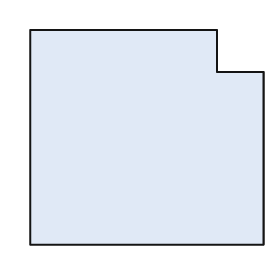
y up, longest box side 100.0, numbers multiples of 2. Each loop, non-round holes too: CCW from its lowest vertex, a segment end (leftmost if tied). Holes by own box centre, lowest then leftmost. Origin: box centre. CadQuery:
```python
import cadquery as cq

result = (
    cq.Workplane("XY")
    .moveTo(-50.0, -46.0)
    .lineTo(50.0, -46.0)
    .lineTo(50.0, 28.0)
    .lineTo(30.0, 28.0)
    .lineTo(30.0, 46.0)
    .lineTo(-50.0, 46.0)
    .close()
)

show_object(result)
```